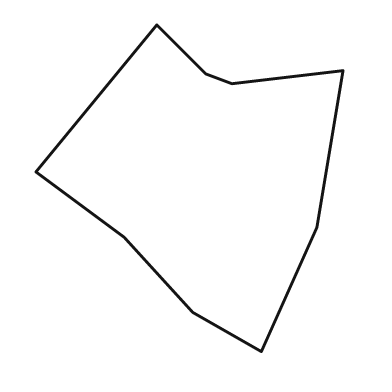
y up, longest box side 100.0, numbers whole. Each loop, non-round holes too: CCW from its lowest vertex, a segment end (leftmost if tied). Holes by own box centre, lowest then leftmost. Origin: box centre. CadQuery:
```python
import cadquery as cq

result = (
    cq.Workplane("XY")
    .moveTo(22.0, -50.0)
    .lineTo(39.0, -12.0)
    .lineTo(47.0, 36.0)
    .lineTo(13.0, 32.0)
    .lineTo(5.0, 35.0)
    .lineTo(-10.0, 50.0)
    .lineTo(-47.0, 5.0)
    .lineTo(-20.0, -15.0)
    .lineTo(1.0, -38.0)
    .close()
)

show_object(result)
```